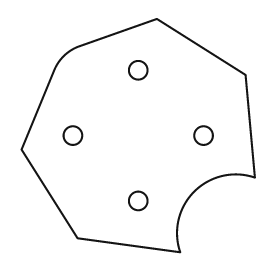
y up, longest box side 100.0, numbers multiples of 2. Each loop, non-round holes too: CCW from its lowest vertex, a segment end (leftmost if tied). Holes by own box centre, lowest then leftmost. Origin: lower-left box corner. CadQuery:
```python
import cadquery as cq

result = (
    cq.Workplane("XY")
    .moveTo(68.0, 0.0)
    .threePointArc((74.0, 26.0), (100.0, 32.0))
    .lineTo(96.0, 76.0)
    .lineTo(58.0, 100.0)
    .lineTo(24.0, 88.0)
    .threePointArc((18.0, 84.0), (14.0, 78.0))
    .lineTo(0.0, 44.0)
    .lineTo(24.0, 6.0)
    .close()
    .moveTo(50.0, 22.0)
    .circle(4.0)
    .moveTo(22.0, 50.0)
    .circle(4.0)
    .moveTo(78.0, 50.0)
    .circle(4.0)
    .moveTo(50.0, 78.0)
    .circle(4.0)
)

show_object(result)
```